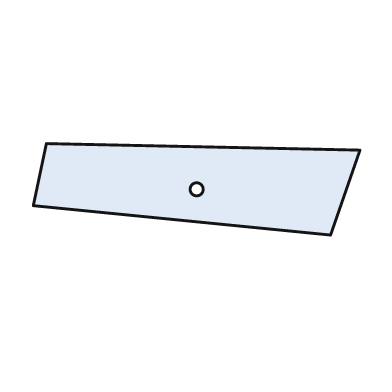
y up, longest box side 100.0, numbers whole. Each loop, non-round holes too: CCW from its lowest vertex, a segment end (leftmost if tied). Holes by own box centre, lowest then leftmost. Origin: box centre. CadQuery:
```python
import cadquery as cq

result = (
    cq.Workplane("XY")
    .moveTo(41.0, -14.0)
    .lineTo(50.0, 12.0)
    .lineTo(-46.0, 14.0)
    .lineTo(-50.0, -5.0)
    .close()
    .moveTo(0.0, 0.0)
    .circle(2.0)
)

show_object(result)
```